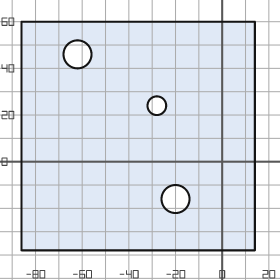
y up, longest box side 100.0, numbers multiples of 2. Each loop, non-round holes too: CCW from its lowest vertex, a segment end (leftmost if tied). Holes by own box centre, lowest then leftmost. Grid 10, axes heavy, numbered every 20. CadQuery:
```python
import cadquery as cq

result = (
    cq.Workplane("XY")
    .moveTo(-86.0, -38.0)
    .lineTo(14.0, -38.0)
    .lineTo(14.0, 60.0)
    .lineTo(-86.0, 60.0)
    .close()
    .moveTo(-20.0, -16.0)
    .circle(6.0)
    .moveTo(-28.0, 24.0)
    .circle(4.0)
    .moveTo(-62.0, 46.0)
    .circle(6.0)
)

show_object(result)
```